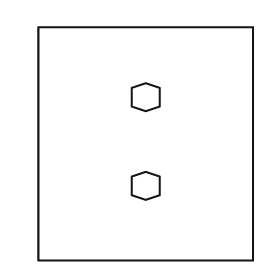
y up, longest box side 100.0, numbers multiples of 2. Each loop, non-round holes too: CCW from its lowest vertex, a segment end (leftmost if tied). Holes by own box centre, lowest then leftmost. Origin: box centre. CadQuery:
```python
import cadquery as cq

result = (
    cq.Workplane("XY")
    .moveTo(-46.0, -50.0)
    .lineTo(46.0, -50.0)
    .lineTo(46.0, 50.0)
    .lineTo(-46.0, 50.0)
    .close()
    .moveTo(0.0, -24.0)
    .lineTo(6.0, -22.0)
    .lineTo(6.0, -14.0)
    .lineTo(0.0, -12.0)
    .lineTo(-6.0, -14.0)
    .lineTo(-6.0, -22.0)
    .close()
    .moveTo(0.0, 14.0)
    .lineTo(6.0, 16.0)
    .lineTo(6.0, 24.0)
    .lineTo(0.0, 26.0)
    .lineTo(-6.0, 24.0)
    .lineTo(-6.0, 16.0)
    .close()
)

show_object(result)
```